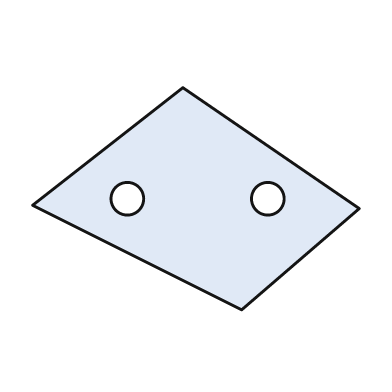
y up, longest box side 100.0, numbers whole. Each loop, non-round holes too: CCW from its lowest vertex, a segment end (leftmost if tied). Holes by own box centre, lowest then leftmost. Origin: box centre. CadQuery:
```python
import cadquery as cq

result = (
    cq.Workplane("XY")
    .moveTo(14.0, -34.0)
    .lineTo(50.0, -3.0)
    .lineTo(-4.0, 34.0)
    .lineTo(-50.0, -2.0)
    .close()
    .moveTo(-21.0, 0.0)
    .circle(5.0)
    .moveTo(22.0, 0.0)
    .circle(5.0)
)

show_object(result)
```